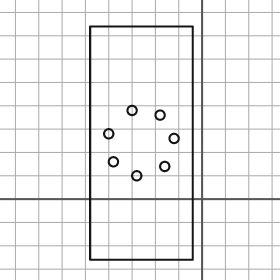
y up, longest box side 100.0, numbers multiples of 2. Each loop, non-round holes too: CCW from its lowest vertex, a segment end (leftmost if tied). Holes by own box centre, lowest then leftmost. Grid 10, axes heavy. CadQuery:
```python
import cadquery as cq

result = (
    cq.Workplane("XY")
    .moveTo(-48.0, -26.0)
    .lineTo(-4.0, -26.0)
    .lineTo(-4.0, 74.0)
    .lineTo(-48.0, 74.0)
    .close()
    .moveTo(-28.0, 10.0)
    .circle(2.0)
    .moveTo(-16.0, 14.0)
    .circle(2.0)
    .moveTo(-38.0, 16.0)
    .circle(2.0)
    .moveTo(-12.0, 26.0)
    .circle(2.0)
    .moveTo(-40.0, 28.0)
    .circle(2.0)
    .moveTo(-18.0, 36.0)
    .circle(2.0)
    .moveTo(-30.0, 38.0)
    .circle(2.0)
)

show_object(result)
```